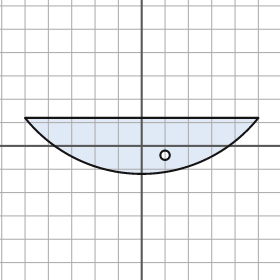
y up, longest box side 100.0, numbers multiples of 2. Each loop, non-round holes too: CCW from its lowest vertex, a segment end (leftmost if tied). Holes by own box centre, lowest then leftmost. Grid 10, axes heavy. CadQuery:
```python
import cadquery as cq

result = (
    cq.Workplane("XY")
    .moveTo(-50.0, 12.0)
    .threePointArc((0.0, -12.0), (50.0, 12.0))
    .close()
    .moveTo(10.0, -4.0)
    .circle(2.0)
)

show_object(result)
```